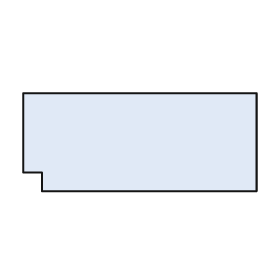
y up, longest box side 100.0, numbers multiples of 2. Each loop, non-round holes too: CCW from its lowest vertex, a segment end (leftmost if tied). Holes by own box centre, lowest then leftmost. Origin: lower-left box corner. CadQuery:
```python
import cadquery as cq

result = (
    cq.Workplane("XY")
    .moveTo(8.0, 0.0)
    .lineTo(100.0, 0.0)
    .lineTo(100.0, 42.0)
    .lineTo(0.0, 42.0)
    .lineTo(0.0, 8.0)
    .lineTo(8.0, 8.0)
    .close()
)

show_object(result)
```